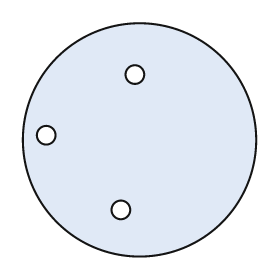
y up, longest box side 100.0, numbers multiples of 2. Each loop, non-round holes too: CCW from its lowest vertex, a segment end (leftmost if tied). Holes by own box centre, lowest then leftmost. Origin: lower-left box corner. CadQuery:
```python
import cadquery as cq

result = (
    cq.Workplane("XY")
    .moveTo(50.0, 50.0)
    .circle(50.0)
    .moveTo(42.0, 20.0)
    .circle(4.0)
    .moveTo(10.0, 52.0)
    .circle(4.0)
    .moveTo(48.0, 78.0)
    .circle(4.0)
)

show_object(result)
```